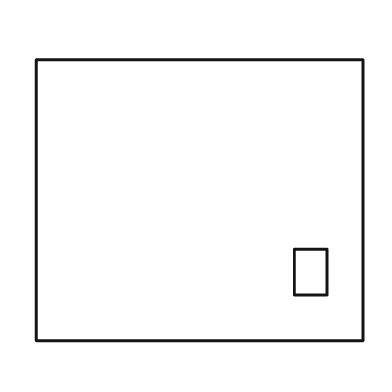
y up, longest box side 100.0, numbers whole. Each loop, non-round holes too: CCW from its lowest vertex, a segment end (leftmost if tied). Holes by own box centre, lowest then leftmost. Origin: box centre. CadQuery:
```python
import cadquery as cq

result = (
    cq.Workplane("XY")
    .moveTo(-50.0, -43.0)
    .lineTo(50.0, -43.0)
    .lineTo(50.0, 43.0)
    .lineTo(-50.0, 43.0)
    .close()
    .moveTo(29.0, -29.0)
    .lineTo(39.0, -29.0)
    .lineTo(39.0, -15.0)
    .lineTo(29.0, -15.0)
    .close()
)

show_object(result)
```